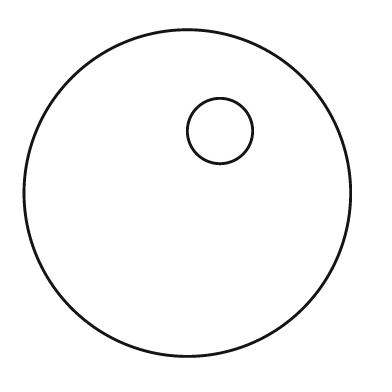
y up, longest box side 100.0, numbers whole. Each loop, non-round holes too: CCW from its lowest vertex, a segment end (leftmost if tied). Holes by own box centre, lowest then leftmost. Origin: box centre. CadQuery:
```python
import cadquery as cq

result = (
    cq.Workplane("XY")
    .moveTo(0.0, 0.0)
    .circle(50.0)
    .moveTo(10.0, 19.0)
    .circle(10.0)
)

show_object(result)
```